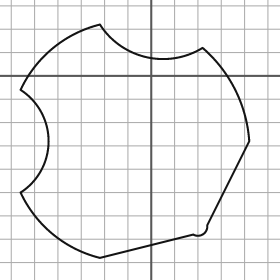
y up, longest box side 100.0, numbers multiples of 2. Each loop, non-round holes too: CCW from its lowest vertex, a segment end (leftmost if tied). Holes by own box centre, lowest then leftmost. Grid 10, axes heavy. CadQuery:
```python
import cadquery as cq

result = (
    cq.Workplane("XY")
    .moveTo(-22.0, -78.0)
    .lineTo(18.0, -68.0)
    .threePointArc((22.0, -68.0), (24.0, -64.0))
    .lineTo(42.0, -28.0)
    .threePointArc((36.0, -6.0), (22.0, 12.0))
    .threePointArc((-2.0, 8.0), (-22.0, 22.0))
    .threePointArc((-42.0, 12.0), (-56.0, -6.0))
    .threePointArc((-44.0, -28.0), (-56.0, -50.0))
    .threePointArc((-42.0, -68.0), (-22.0, -78.0))
    .close()
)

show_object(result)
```